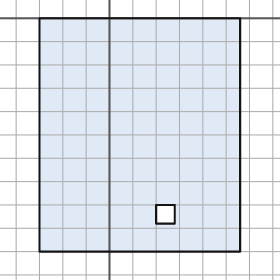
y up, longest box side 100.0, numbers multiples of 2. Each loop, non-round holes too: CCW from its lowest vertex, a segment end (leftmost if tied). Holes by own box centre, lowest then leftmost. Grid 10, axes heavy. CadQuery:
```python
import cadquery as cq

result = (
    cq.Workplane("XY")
    .moveTo(-30.0, -100.0)
    .lineTo(56.0, -100.0)
    .lineTo(56.0, 0.0)
    .lineTo(-30.0, 0.0)
    .close()
    .moveTo(20.0, -88.0)
    .lineTo(28.0, -88.0)
    .lineTo(28.0, -80.0)
    .lineTo(20.0, -80.0)
    .close()
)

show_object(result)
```